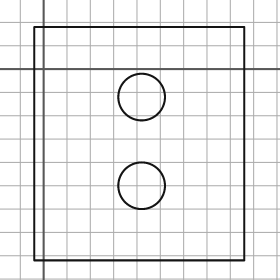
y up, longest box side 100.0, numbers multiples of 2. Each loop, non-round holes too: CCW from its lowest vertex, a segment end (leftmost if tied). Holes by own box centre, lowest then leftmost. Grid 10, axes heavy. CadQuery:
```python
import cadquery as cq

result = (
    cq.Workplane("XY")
    .moveTo(-4.0, -82.0)
    .lineTo(86.0, -82.0)
    .lineTo(86.0, 18.0)
    .lineTo(-4.0, 18.0)
    .close()
    .moveTo(42.0, -50.0)
    .circle(10.0)
    .moveTo(42.0, -12.0)
    .circle(10.0)
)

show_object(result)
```